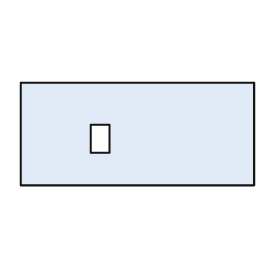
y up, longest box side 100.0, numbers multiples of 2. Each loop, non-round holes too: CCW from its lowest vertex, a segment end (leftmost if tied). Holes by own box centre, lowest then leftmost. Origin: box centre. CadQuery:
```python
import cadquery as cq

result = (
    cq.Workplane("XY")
    .moveTo(-50.0, -22.0)
    .lineTo(50.0, -22.0)
    .lineTo(50.0, 22.0)
    .lineTo(-50.0, 22.0)
    .close()
    .moveTo(-20.0, -8.0)
    .lineTo(-12.0, -8.0)
    .lineTo(-12.0, 4.0)
    .lineTo(-20.0, 4.0)
    .close()
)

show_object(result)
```